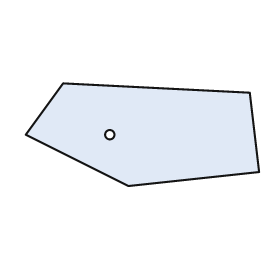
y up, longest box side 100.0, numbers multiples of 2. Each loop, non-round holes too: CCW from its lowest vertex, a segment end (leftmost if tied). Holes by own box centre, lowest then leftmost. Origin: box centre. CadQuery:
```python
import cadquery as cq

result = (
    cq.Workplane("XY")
    .moveTo(-6.0, -22.0)
    .lineTo(50.0, -16.0)
    .lineTo(46.0, 18.0)
    .lineTo(-34.0, 22.0)
    .lineTo(-50.0, 0.0)
    .close()
    .moveTo(-14.0, 0.0)
    .circle(2.0)
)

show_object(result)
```